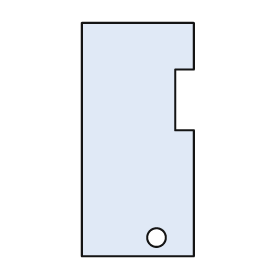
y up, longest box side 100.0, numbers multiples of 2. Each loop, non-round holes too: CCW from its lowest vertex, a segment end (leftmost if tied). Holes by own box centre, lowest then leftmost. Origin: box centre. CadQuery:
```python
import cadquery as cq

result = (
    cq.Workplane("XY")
    .moveTo(-24.0, -50.0)
    .lineTo(24.0, -50.0)
    .lineTo(24.0, 4.0)
    .lineTo(16.0, 4.0)
    .lineTo(16.0, 30.0)
    .lineTo(24.0, 30.0)
    .lineTo(24.0, 50.0)
    .lineTo(-24.0, 50.0)
    .close()
    .moveTo(8.0, -42.0)
    .circle(4.0)
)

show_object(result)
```